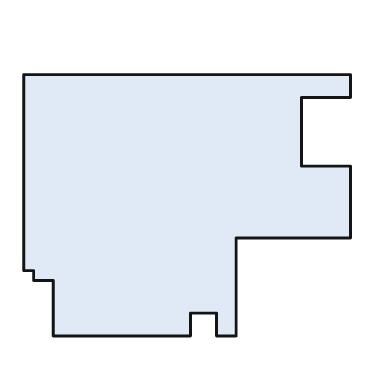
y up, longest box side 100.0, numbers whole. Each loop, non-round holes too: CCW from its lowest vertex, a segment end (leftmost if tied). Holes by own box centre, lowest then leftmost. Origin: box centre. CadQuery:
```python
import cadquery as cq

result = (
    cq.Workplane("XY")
    .moveTo(-41.0, -40.0)
    .lineTo(1.0, -40.0)
    .lineTo(1.0, -33.0)
    .lineTo(9.0, -33.0)
    .lineTo(9.0, -40.0)
    .lineTo(15.0, -40.0)
    .lineTo(15.0, -10.0)
    .lineTo(50.0, -10.0)
    .lineTo(50.0, 12.0)
    .lineTo(35.0, 12.0)
    .lineTo(35.0, 33.0)
    .lineTo(50.0, 33.0)
    .lineTo(50.0, 40.0)
    .lineTo(-50.0, 40.0)
    .lineTo(-50.0, -20.0)
    .lineTo(-47.0, -20.0)
    .lineTo(-47.0, -23.0)
    .lineTo(-41.0, -23.0)
    .close()
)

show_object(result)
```